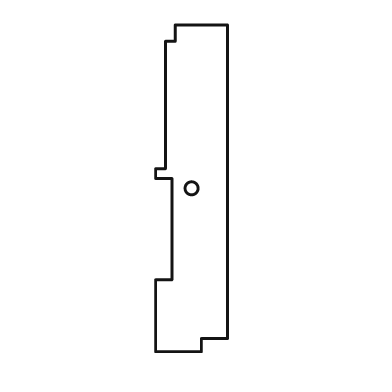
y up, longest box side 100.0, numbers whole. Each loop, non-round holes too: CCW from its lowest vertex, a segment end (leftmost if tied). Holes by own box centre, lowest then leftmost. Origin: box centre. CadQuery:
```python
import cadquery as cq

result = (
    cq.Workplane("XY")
    .moveTo(-11.0, -50.0)
    .lineTo(3.0, -50.0)
    .lineTo(3.0, -46.0)
    .lineTo(11.0, -46.0)
    .lineTo(11.0, 50.0)
    .lineTo(-5.0, 50.0)
    .lineTo(-5.0, 45.0)
    .lineTo(-8.0, 45.0)
    .lineTo(-8.0, 6.0)
    .lineTo(-11.0, 6.0)
    .lineTo(-11.0, 3.0)
    .lineTo(-6.0, 3.0)
    .lineTo(-6.0, -28.0)
    .lineTo(-11.0, -28.0)
    .close()
    .moveTo(0.0, 0.0)
    .circle(2.0)
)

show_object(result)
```